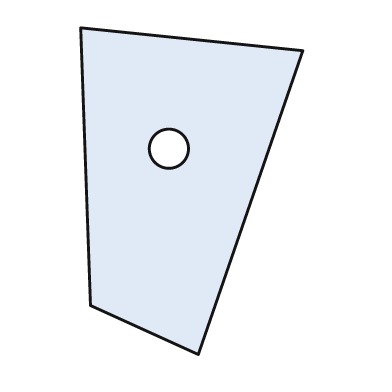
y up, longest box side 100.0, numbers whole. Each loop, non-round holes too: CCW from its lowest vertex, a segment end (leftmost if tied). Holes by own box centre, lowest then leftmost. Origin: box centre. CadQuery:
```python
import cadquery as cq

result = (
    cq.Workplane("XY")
    .moveTo(2.0, -50.0)
    .lineTo(34.0, 43.0)
    .lineTo(-34.0, 50.0)
    .lineTo(-31.0, -35.0)
    .close()
    .moveTo(-7.0, 13.0)
    .circle(6.0)
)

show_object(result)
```